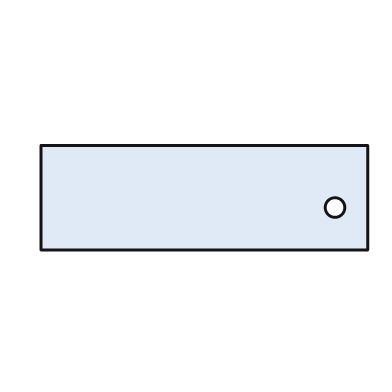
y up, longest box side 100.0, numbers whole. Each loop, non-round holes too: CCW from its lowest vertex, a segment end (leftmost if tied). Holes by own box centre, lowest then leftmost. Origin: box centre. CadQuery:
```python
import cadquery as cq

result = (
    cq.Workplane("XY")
    .moveTo(-50.0, -16.0)
    .lineTo(50.0, -16.0)
    .lineTo(50.0, 16.0)
    .lineTo(-50.0, 16.0)
    .close()
    .moveTo(40.0, -3.0)
    .circle(3.0)
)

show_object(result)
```